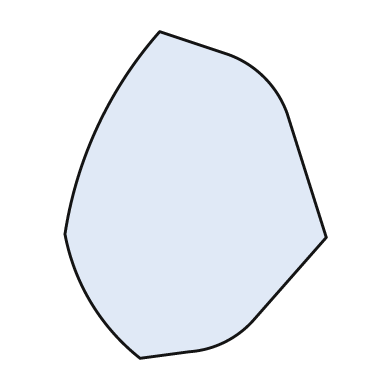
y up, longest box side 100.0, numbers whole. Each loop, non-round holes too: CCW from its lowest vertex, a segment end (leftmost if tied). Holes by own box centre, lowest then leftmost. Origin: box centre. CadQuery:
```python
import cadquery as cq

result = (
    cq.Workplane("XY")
    .moveTo(-17.0, -50.0)
    .lineTo(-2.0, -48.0)
    .threePointArc((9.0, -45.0), (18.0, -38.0))
    .lineTo(40.0, -13.0)
    .lineTo(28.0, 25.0)
    .threePointArc((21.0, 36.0), (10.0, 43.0))
    .lineTo(-11.0, 50.0)
    .threePointArc((-30.0, 21.0), (-40.0, -12.0))
    .threePointArc((-32.0, -33.0), (-17.0, -50.0))
    .close()
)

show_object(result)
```